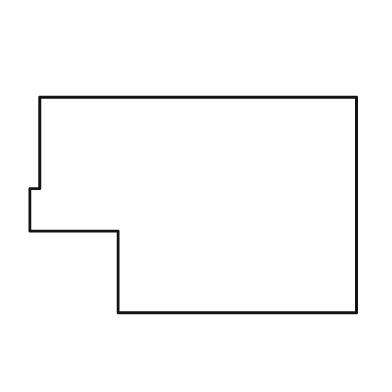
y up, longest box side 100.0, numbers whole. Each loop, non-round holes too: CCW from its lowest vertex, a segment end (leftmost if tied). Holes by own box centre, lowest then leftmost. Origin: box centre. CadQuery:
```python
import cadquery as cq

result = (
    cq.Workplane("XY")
    .moveTo(-23.0, -33.0)
    .lineTo(50.0, -33.0)
    .lineTo(50.0, 33.0)
    .lineTo(-47.0, 33.0)
    .lineTo(-47.0, 5.0)
    .lineTo(-50.0, 5.0)
    .lineTo(-50.0, -8.0)
    .lineTo(-23.0, -8.0)
    .close()
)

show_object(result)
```